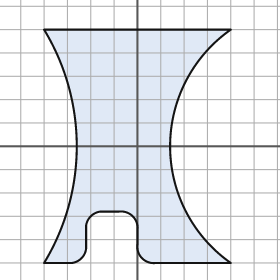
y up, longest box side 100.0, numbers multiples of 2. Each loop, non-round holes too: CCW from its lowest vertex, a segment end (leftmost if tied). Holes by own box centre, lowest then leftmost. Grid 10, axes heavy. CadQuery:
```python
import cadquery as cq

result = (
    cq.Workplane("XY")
    .moveTo(-40.0, -50.0)
    .lineTo(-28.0, -50.0)
    .threePointArc((-24.0, -48.0), (-22.0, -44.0))
    .lineTo(-22.0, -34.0)
    .threePointArc((-20.0, -30.0), (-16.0, -28.0))
    .lineTo(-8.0, -28.0)
    .threePointArc((-2.0, -30.0), (0.0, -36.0))
    .lineTo(0.0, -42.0)
    .threePointArc((2.0, -48.0), (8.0, -50.0))
    .lineTo(40.0, -50.0)
    .threePointArc((14.0, 0.0), (40.0, 50.0))
    .lineTo(-40.0, 50.0)
    .threePointArc((-26.0, 0.0), (-40.0, -50.0))
    .close()
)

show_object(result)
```